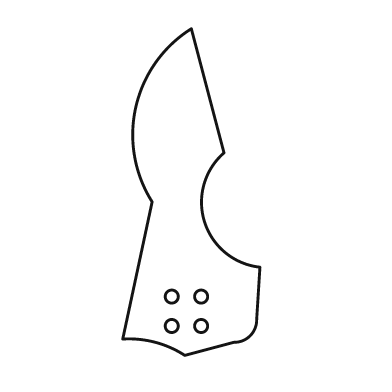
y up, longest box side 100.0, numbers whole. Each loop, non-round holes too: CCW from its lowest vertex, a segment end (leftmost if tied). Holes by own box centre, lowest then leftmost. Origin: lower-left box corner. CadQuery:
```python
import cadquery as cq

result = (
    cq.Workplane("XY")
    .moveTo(19.0, 0.0)
    .lineTo(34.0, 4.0)
    .threePointArc((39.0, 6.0), (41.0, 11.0))
    .lineTo(42.0, 27.0)
    .threePointArc((25.0, 41.0), (31.0, 62.0))
    .lineTo(21.0, 100.0)
    .threePointArc((4.0, 76.0), (9.0, 47.0))
    .lineTo(0.0, 5.0)
    .threePointArc((10.0, 4.0), (19.0, 0.0))
    .close()
    .moveTo(15.0, 9.0)
    .circle(2.0)
    .moveTo(24.0, 9.0)
    .circle(2.0)
    .moveTo(15.0, 18.0)
    .circle(2.0)
    .moveTo(24.0, 18.0)
    .circle(2.0)
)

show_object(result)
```